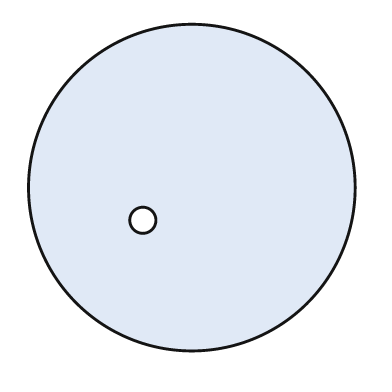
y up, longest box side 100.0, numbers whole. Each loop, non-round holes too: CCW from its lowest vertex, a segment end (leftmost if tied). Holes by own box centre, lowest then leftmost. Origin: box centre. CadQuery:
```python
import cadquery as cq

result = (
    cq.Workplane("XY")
    .moveTo(0.0, 0.0)
    .circle(50.0)
    .moveTo(-15.0, -10.0)
    .circle(4.0)
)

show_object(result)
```